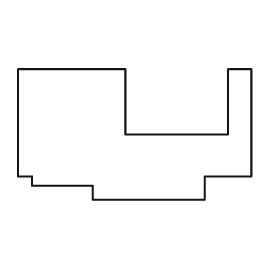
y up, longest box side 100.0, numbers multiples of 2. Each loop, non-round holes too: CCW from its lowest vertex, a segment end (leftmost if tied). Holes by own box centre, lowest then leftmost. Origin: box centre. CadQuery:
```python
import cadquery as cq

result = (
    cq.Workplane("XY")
    .moveTo(-18.0, -28.0)
    .lineTo(30.0, -28.0)
    .lineTo(30.0, -18.0)
    .lineTo(50.0, -18.0)
    .lineTo(50.0, 28.0)
    .lineTo(40.0, 28.0)
    .lineTo(40.0, 0.0)
    .lineTo(-4.0, 0.0)
    .lineTo(-4.0, 28.0)
    .lineTo(-50.0, 28.0)
    .lineTo(-50.0, -18.0)
    .lineTo(-44.0, -18.0)
    .lineTo(-44.0, -22.0)
    .lineTo(-18.0, -22.0)
    .close()
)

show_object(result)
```